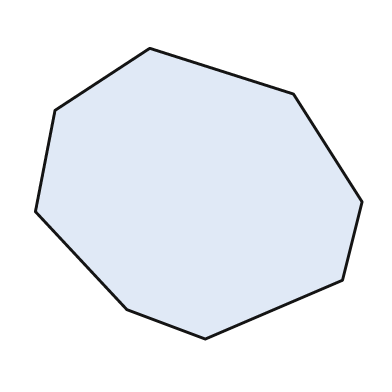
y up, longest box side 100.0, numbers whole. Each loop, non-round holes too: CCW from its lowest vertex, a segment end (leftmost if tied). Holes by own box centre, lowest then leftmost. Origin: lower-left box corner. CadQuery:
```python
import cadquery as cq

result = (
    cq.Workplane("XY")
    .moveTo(52.0, 0.0)
    .lineTo(94.0, 18.0)
    .lineTo(100.0, 42.0)
    .lineTo(79.0, 75.0)
    .lineTo(35.0, 89.0)
    .lineTo(6.0, 70.0)
    .lineTo(0.0, 39.0)
    .lineTo(28.0, 9.0)
    .close()
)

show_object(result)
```